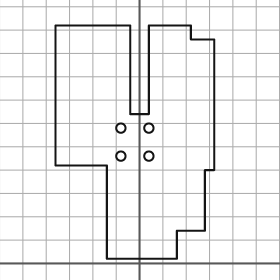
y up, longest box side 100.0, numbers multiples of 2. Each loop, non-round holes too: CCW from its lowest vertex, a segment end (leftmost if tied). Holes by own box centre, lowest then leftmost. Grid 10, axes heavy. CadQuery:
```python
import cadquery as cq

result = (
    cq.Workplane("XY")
    .moveTo(-14.0, 2.0)
    .lineTo(16.0, 2.0)
    .lineTo(16.0, 14.0)
    .lineTo(28.0, 14.0)
    .lineTo(28.0, 40.0)
    .lineTo(32.0, 40.0)
    .lineTo(32.0, 96.0)
    .lineTo(22.0, 96.0)
    .lineTo(22.0, 102.0)
    .lineTo(4.0, 102.0)
    .lineTo(4.0, 64.0)
    .lineTo(-4.0, 64.0)
    .lineTo(-4.0, 102.0)
    .lineTo(-36.0, 102.0)
    .lineTo(-36.0, 42.0)
    .lineTo(-14.0, 42.0)
    .close()
    .moveTo(-8.0, 46.0)
    .circle(2.0)
    .moveTo(4.0, 46.0)
    .circle(2.0)
    .moveTo(-8.0, 58.0)
    .circle(2.0)
    .moveTo(4.0, 58.0)
    .circle(2.0)
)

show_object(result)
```